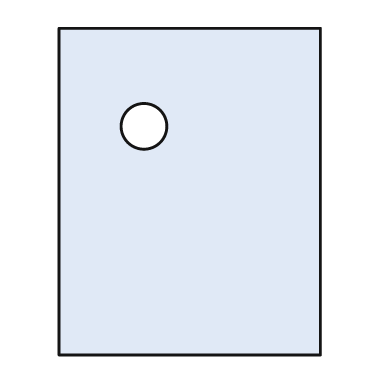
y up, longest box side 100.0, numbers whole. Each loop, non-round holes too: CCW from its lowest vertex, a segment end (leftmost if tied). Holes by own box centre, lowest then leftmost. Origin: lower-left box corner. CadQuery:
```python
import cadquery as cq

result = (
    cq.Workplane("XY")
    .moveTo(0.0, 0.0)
    .lineTo(80.0, 0.0)
    .lineTo(80.0, 100.0)
    .lineTo(0.0, 100.0)
    .close()
    .moveTo(26.0, 70.0)
    .circle(7.0)
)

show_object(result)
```